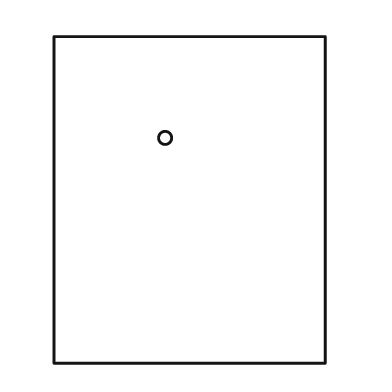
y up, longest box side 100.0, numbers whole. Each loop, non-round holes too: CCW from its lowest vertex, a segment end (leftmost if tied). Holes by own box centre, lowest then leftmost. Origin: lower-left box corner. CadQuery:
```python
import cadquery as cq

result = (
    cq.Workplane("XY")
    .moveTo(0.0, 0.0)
    .lineTo(83.0, 0.0)
    .lineTo(83.0, 100.0)
    .lineTo(0.0, 100.0)
    .close()
    .moveTo(34.0, 69.0)
    .circle(2.0)
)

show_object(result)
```